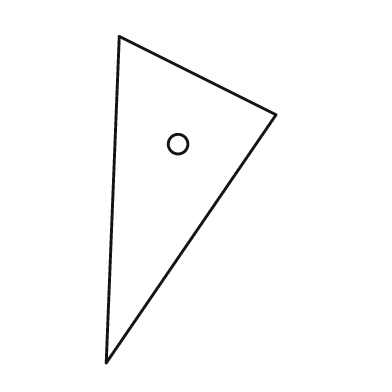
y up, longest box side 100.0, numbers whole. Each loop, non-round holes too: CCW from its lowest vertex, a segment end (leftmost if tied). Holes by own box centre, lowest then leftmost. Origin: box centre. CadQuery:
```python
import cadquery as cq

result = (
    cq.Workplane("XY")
    .moveTo(-26.0, -50.0)
    .lineTo(26.0, 26.0)
    .lineTo(-22.0, 50.0)
    .close()
    .moveTo(-4.0, 17.0)
    .circle(3.0)
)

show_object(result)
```